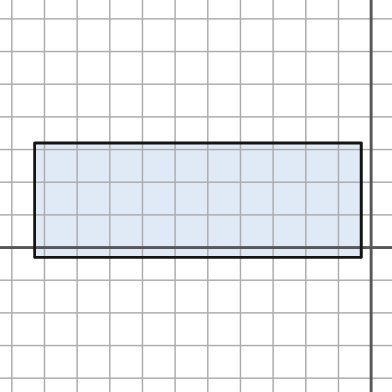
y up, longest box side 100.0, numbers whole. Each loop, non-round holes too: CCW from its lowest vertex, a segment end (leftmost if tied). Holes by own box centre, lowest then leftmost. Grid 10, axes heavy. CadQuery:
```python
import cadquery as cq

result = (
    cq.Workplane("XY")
    .moveTo(-103.0, -3.0)
    .lineTo(-3.0, -3.0)
    .lineTo(-3.0, 32.0)
    .lineTo(-103.0, 32.0)
    .close()
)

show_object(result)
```